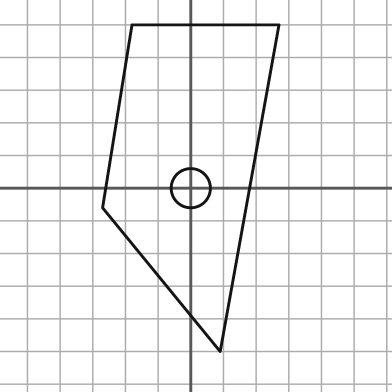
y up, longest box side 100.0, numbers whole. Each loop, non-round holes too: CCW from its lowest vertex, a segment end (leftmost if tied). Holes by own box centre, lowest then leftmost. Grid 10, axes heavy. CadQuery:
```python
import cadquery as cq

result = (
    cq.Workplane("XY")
    .moveTo(9.0, -50.0)
    .lineTo(27.0, 50.0)
    .lineTo(-18.0, 50.0)
    .lineTo(-27.0, -6.0)
    .close()
    .moveTo(0.0, 0.0)
    .circle(6.0)
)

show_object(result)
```